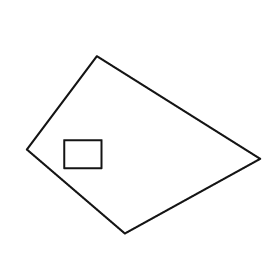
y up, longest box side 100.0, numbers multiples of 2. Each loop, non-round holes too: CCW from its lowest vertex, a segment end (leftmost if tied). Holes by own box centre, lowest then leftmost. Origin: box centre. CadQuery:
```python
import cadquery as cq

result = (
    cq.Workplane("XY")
    .moveTo(-8.0, -38.0)
    .lineTo(50.0, -6.0)
    .lineTo(-20.0, 38.0)
    .lineTo(-50.0, -2.0)
    .close()
    .moveTo(-34.0, -10.0)
    .lineTo(-18.0, -10.0)
    .lineTo(-18.0, 2.0)
    .lineTo(-34.0, 2.0)
    .close()
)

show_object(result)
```